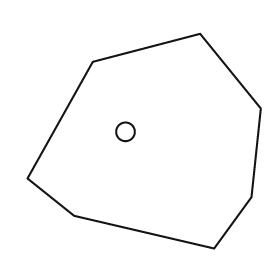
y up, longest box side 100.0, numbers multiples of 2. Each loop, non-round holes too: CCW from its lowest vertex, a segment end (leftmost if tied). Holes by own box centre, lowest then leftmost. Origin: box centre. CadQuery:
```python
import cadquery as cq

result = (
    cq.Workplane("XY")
    .moveTo(30.0, -46.0)
    .lineTo(46.0, -24.0)
    .lineTo(50.0, 14.0)
    .lineTo(24.0, 46.0)
    .lineTo(-22.0, 34.0)
    .lineTo(-50.0, -16.0)
    .lineTo(-30.0, -32.0)
    .close()
    .moveTo(-8.0, 4.0)
    .circle(4.0)
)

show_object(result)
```